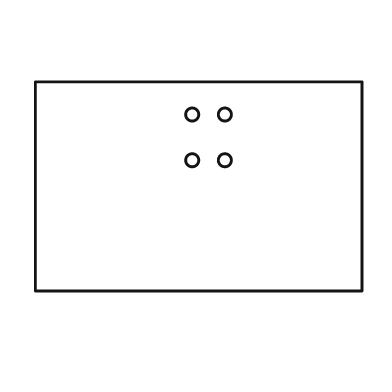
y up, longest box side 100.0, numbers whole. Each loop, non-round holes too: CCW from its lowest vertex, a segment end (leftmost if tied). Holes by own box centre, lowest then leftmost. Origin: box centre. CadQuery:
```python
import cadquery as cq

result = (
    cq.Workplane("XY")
    .moveTo(-50.0, -32.0)
    .lineTo(50.0, -32.0)
    .lineTo(50.0, 32.0)
    .lineTo(-50.0, 32.0)
    .close()
    .moveTo(-2.0, 8.0)
    .circle(2.0)
    .moveTo(8.0, 8.0)
    .circle(2.0)
    .moveTo(-2.0, 22.0)
    .circle(2.0)
    .moveTo(8.0, 22.0)
    .circle(2.0)
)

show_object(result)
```